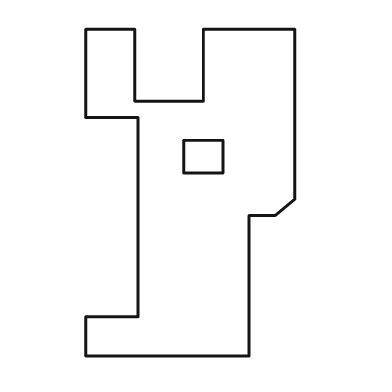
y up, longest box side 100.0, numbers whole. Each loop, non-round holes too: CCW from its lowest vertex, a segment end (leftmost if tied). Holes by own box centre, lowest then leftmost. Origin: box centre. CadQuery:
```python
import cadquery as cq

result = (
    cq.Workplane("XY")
    .moveTo(-32.0, -50.0)
    .lineTo(18.0, -50.0)
    .lineTo(18.0, -7.0)
    .lineTo(26.0, -7.0)
    .lineTo(32.0, -2.0)
    .lineTo(32.0, 50.0)
    .lineTo(4.0, 50.0)
    .lineTo(4.0, 28.0)
    .lineTo(-17.0, 28.0)
    .lineTo(-17.0, 50.0)
    .lineTo(-32.0, 50.0)
    .lineTo(-32.0, 23.0)
    .lineTo(-16.0, 23.0)
    .lineTo(-16.0, -38.0)
    .lineTo(-32.0, -38.0)
    .close()
    .moveTo(-2.0, 6.0)
    .lineTo(10.0, 6.0)
    .lineTo(10.0, 16.0)
    .lineTo(-2.0, 16.0)
    .close()
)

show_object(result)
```